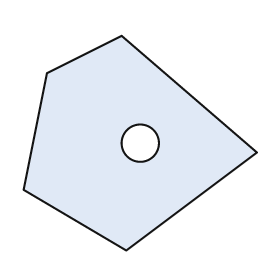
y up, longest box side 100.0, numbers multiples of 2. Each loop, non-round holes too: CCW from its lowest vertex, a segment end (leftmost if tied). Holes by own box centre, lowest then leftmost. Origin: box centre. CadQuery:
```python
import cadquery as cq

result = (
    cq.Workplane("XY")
    .moveTo(-6.0, -46.0)
    .lineTo(50.0, -4.0)
    .lineTo(-8.0, 46.0)
    .lineTo(-40.0, 30.0)
    .lineTo(-50.0, -20.0)
    .close()
    .moveTo(0.0, 0.0)
    .circle(8.0)
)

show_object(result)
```